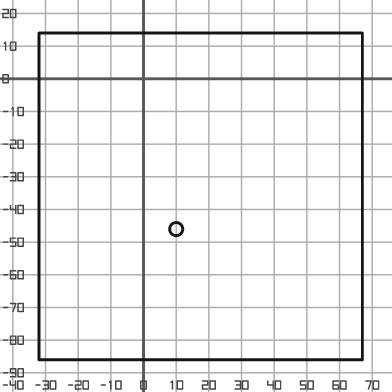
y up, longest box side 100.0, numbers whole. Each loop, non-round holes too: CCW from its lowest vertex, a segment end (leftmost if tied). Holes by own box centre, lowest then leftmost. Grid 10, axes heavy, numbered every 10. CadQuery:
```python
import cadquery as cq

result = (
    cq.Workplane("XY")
    .moveTo(-32.0, -86.0)
    .lineTo(67.0, -86.0)
    .lineTo(67.0, 14.0)
    .lineTo(-32.0, 14.0)
    .close()
    .moveTo(10.0, -46.0)
    .circle(2.0)
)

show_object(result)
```